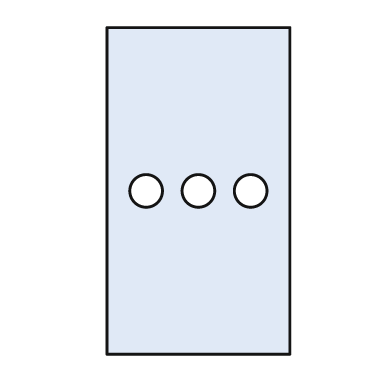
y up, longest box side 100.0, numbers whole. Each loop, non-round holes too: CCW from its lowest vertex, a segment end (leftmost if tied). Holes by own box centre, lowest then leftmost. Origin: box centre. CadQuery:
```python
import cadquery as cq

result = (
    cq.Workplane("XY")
    .moveTo(-28.0, -50.0)
    .lineTo(28.0, -50.0)
    .lineTo(28.0, 50.0)
    .lineTo(-28.0, 50.0)
    .close()
    .moveTo(-16.0, 0.0)
    .circle(5.0)
    .moveTo(0.0, 0.0)
    .circle(5.0)
    .moveTo(16.0, 0.0)
    .circle(5.0)
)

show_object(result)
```